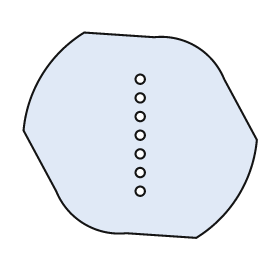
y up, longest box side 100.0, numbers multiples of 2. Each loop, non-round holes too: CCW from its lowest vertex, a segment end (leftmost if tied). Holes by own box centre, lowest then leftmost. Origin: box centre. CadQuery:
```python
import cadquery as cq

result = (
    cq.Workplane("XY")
    .moveTo(24.0, -44.0)
    .threePointArc((42.0, -26.0), (50.0, -2.0))
    .lineTo(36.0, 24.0)
    .threePointArc((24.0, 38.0), (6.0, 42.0))
    .lineTo(-24.0, 44.0)
    .threePointArc((-42.0, 26.0), (-50.0, 2.0))
    .lineTo(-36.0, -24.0)
    .threePointArc((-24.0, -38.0), (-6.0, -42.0))
    .close()
    .moveTo(0.0, -24.0)
    .circle(2.0)
    .moveTo(0.0, -16.0)
    .circle(2.0)
    .moveTo(0.0, -8.0)
    .circle(2.0)
    .moveTo(0.0, 0.0)
    .circle(2.0)
    .moveTo(0.0, 8.0)
    .circle(2.0)
    .moveTo(0.0, 16.0)
    .circle(2.0)
    .moveTo(0.0, 24.0)
    .circle(2.0)
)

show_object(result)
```